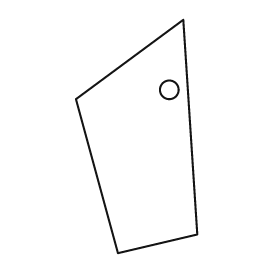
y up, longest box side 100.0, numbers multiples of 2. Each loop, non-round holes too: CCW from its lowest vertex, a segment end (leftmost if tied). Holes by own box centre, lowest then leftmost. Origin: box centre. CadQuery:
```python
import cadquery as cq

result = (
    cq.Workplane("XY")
    .moveTo(-8.0, -50.0)
    .lineTo(26.0, -42.0)
    .lineTo(20.0, 50.0)
    .lineTo(-26.0, 16.0)
    .close()
    .moveTo(14.0, 20.0)
    .circle(4.0)
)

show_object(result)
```